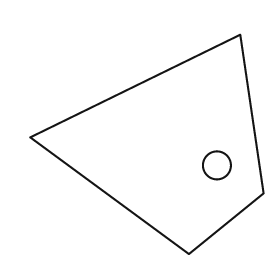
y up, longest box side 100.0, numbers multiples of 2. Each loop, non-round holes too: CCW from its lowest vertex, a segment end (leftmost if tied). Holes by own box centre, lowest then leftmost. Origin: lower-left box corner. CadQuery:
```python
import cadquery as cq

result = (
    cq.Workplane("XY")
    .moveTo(68.0, 0.0)
    .lineTo(100.0, 26.0)
    .lineTo(90.0, 94.0)
    .lineTo(0.0, 50.0)
    .close()
    .moveTo(80.0, 38.0)
    .circle(6.0)
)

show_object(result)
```